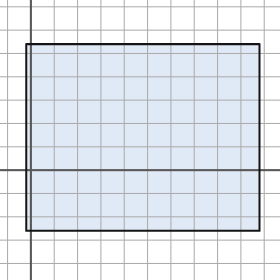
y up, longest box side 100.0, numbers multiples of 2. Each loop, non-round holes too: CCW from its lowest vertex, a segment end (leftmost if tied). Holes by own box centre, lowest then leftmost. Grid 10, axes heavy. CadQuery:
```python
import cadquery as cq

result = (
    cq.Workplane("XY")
    .moveTo(-2.0, -26.0)
    .lineTo(98.0, -26.0)
    .lineTo(98.0, 54.0)
    .lineTo(-2.0, 54.0)
    .close()
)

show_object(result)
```